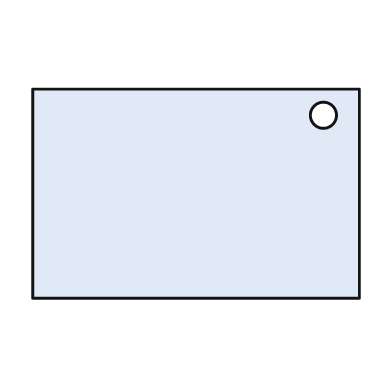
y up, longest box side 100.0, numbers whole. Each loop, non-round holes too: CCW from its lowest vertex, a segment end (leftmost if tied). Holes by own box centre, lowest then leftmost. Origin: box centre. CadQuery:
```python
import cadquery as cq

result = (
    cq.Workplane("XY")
    .moveTo(-50.0, -32.0)
    .lineTo(50.0, -32.0)
    .lineTo(50.0, 32.0)
    .lineTo(-50.0, 32.0)
    .close()
    .moveTo(39.0, 24.0)
    .circle(4.0)
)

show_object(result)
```